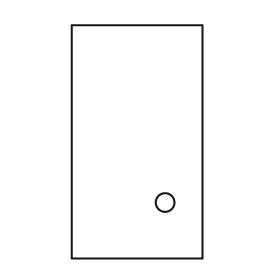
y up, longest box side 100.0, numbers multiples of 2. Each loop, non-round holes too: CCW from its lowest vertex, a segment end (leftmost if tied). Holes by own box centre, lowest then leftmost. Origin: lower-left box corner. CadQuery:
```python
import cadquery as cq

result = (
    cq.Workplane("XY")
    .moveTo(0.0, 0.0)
    .lineTo(56.0, 0.0)
    .lineTo(56.0, 100.0)
    .lineTo(0.0, 100.0)
    .close()
    .moveTo(40.0, 24.0)
    .circle(4.0)
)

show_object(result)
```